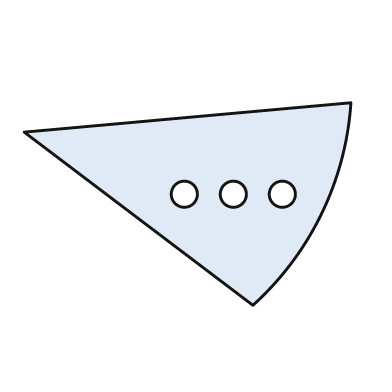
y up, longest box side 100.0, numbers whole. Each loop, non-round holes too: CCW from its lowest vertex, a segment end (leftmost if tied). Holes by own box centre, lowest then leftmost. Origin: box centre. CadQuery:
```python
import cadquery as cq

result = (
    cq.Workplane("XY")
    .moveTo(20.0, -31.0)
    .threePointArc((41.0, -3.0), (50.0, 31.0))
    .lineTo(-50.0, 22.0)
    .close()
    .moveTo(-1.0, 3.0)
    .circle(4.0)
    .moveTo(14.0, 3.0)
    .circle(4.0)
    .moveTo(29.0, 3.0)
    .circle(4.0)
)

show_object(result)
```